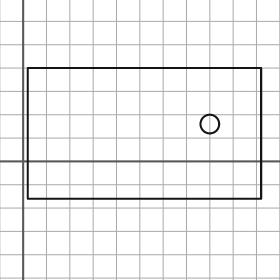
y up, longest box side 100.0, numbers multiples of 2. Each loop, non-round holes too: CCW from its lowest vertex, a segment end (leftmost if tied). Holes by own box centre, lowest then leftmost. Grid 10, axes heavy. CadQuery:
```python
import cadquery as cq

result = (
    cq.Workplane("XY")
    .moveTo(2.0, -16.0)
    .lineTo(102.0, -16.0)
    .lineTo(102.0, 40.0)
    .lineTo(2.0, 40.0)
    .close()
    .moveTo(80.0, 16.0)
    .circle(4.0)
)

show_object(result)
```